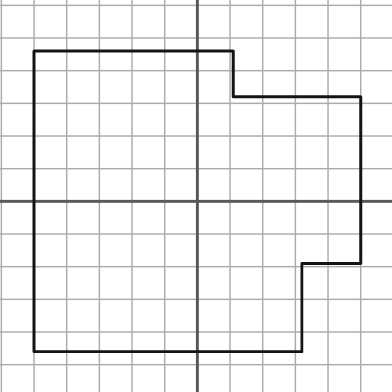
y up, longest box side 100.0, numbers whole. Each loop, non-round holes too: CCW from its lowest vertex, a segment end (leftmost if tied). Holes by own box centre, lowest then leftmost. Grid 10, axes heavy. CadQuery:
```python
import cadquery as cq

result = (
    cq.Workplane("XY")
    .moveTo(-50.0, -46.0)
    .lineTo(32.0, -46.0)
    .lineTo(32.0, -19.0)
    .lineTo(50.0, -19.0)
    .lineTo(50.0, 32.0)
    .lineTo(11.0, 32.0)
    .lineTo(11.0, 46.0)
    .lineTo(-50.0, 46.0)
    .close()
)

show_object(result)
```